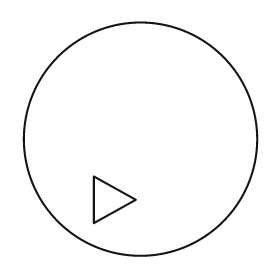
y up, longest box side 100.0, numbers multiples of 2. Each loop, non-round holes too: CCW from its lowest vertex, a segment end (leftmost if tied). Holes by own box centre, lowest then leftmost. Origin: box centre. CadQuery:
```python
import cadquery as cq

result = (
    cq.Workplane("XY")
    .moveTo(0.0, 0.0)
    .circle(50.0)
    .moveTo(-20.0, -36.0)
    .lineTo(-2.0, -26.0)
    .lineTo(-20.0, -16.0)
    .close()
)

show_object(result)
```